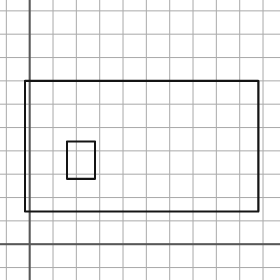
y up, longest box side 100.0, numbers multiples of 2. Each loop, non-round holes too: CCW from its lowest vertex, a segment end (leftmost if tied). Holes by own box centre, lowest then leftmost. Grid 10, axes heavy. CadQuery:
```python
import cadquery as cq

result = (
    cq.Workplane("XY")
    .moveTo(-2.0, 14.0)
    .lineTo(98.0, 14.0)
    .lineTo(98.0, 70.0)
    .lineTo(-2.0, 70.0)
    .close()
    .moveTo(16.0, 28.0)
    .lineTo(28.0, 28.0)
    .lineTo(28.0, 44.0)
    .lineTo(16.0, 44.0)
    .close()
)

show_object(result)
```